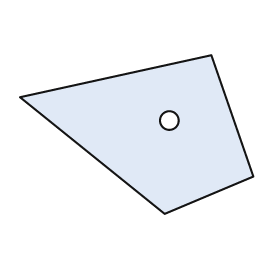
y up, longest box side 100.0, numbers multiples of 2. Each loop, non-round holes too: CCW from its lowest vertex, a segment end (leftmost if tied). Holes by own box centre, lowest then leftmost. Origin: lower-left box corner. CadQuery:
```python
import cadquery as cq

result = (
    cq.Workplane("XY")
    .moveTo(62.0, 0.0)
    .lineTo(100.0, 16.0)
    .lineTo(82.0, 68.0)
    .lineTo(0.0, 50.0)
    .close()
    .moveTo(64.0, 40.0)
    .circle(4.0)
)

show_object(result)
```